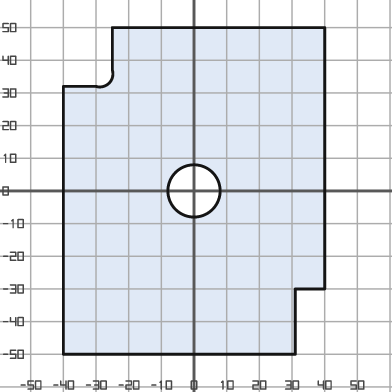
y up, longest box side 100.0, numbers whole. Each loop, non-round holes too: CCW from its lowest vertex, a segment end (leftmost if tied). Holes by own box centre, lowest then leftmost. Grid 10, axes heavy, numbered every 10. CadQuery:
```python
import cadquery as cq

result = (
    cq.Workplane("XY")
    .moveTo(-40.0, -50.0)
    .lineTo(31.0, -50.0)
    .lineTo(31.0, -30.0)
    .lineTo(40.0, -30.0)
    .lineTo(40.0, 50.0)
    .lineTo(-25.0, 50.0)
    .lineTo(-25.0, 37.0)
    .threePointArc((-26.0, 33.0), (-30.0, 32.0))
    .lineTo(-40.0, 32.0)
    .close()
    .moveTo(0.0, 0.0)
    .circle(8.0)
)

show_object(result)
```